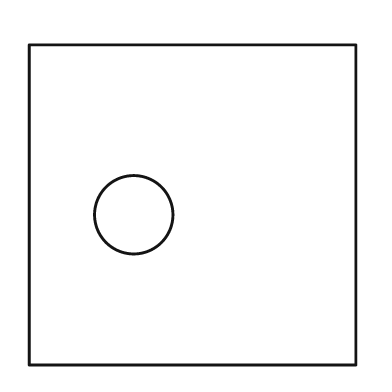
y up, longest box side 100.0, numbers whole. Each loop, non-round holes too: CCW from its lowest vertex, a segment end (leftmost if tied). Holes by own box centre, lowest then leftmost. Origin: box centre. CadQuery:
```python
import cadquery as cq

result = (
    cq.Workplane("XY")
    .moveTo(-50.0, -49.0)
    .lineTo(50.0, -49.0)
    .lineTo(50.0, 49.0)
    .lineTo(-50.0, 49.0)
    .close()
    .moveTo(-18.0, -3.0)
    .circle(12.0)
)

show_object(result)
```